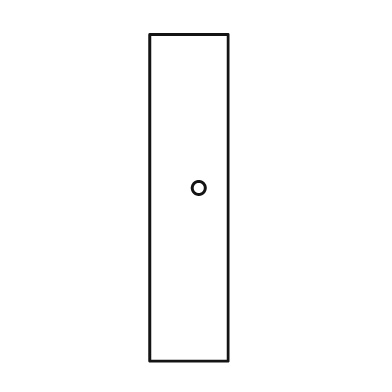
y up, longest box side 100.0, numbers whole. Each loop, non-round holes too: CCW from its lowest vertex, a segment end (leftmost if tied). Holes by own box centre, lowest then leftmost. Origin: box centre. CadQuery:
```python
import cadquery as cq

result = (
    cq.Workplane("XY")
    .moveTo(-12.0, -50.0)
    .lineTo(12.0, -50.0)
    .lineTo(12.0, 50.0)
    .lineTo(-12.0, 50.0)
    .close()
    .moveTo(3.0, 3.0)
    .circle(2.0)
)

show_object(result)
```